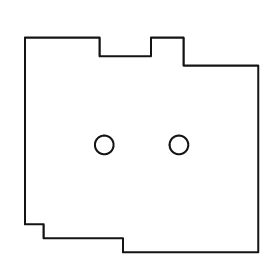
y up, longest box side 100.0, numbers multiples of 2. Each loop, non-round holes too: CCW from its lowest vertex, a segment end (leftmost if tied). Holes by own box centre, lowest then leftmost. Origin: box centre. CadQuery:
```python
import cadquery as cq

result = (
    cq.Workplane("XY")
    .moveTo(-8.0, -46.0)
    .lineTo(50.0, -46.0)
    .lineTo(50.0, 34.0)
    .lineTo(18.0, 34.0)
    .lineTo(18.0, 46.0)
    .lineTo(4.0, 46.0)
    .lineTo(4.0, 38.0)
    .lineTo(-18.0, 38.0)
    .lineTo(-18.0, 46.0)
    .lineTo(-50.0, 46.0)
    .lineTo(-50.0, -34.0)
    .lineTo(-42.0, -34.0)
    .lineTo(-42.0, -40.0)
    .lineTo(-8.0, -40.0)
    .close()
    .moveTo(-16.0, 0.0)
    .circle(4.0)
    .moveTo(16.0, 0.0)
    .circle(4.0)
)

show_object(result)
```